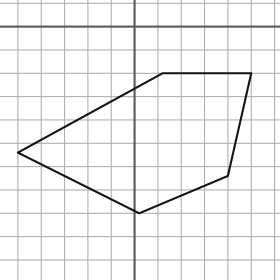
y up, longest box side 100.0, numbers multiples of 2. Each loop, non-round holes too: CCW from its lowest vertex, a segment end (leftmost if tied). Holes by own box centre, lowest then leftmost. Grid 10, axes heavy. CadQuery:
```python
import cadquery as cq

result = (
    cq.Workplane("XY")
    .moveTo(2.0, -80.0)
    .lineTo(40.0, -64.0)
    .lineTo(50.0, -20.0)
    .lineTo(12.0, -20.0)
    .lineTo(-50.0, -54.0)
    .close()
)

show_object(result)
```